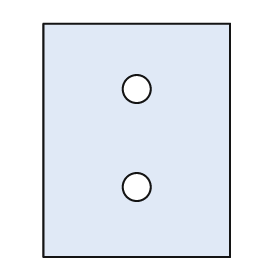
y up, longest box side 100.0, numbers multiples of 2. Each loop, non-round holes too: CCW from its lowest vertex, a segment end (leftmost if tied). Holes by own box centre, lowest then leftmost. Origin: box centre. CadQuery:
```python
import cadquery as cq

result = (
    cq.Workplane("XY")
    .moveTo(-40.0, -50.0)
    .lineTo(40.0, -50.0)
    .lineTo(40.0, 50.0)
    .lineTo(-40.0, 50.0)
    .close()
    .moveTo(0.0, -20.0)
    .circle(6.0)
    .moveTo(0.0, 22.0)
    .circle(6.0)
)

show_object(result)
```